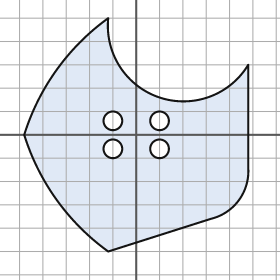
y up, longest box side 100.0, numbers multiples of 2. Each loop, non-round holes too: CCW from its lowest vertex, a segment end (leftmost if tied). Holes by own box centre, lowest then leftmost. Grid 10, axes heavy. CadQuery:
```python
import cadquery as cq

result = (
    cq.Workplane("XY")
    .moveTo(-12.0, -50.0)
    .lineTo(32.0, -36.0)
    .threePointArc((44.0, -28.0), (48.0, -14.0))
    .lineTo(48.0, 30.0)
    .threePointArc((10.0, 16.0), (-12.0, 50.0))
    .threePointArc((-34.0, 28.0), (-48.0, 0.0))
    .threePointArc((-34.0, -28.0), (-12.0, -50.0))
    .close()
    .moveTo(-10.0, -6.0)
    .circle(4.0)
    .moveTo(10.0, -6.0)
    .circle(4.0)
    .moveTo(-10.0, 6.0)
    .circle(4.0)
    .moveTo(10.0, 6.0)
    .circle(4.0)
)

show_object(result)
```